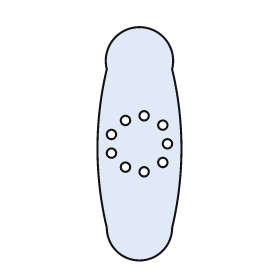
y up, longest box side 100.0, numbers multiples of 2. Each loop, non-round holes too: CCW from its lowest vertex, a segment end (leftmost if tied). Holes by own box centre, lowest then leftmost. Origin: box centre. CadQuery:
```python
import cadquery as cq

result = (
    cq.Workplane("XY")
    .moveTo(-14.0, -36.0)
    .threePointArc((0.0, -50.0), (14.0, -36.0))
    .threePointArc((18.0, -2.0), (14.0, 32.0))
    .threePointArc((0.0, 50.0), (-14.0, 32.0))
    .threePointArc((-18.0, -2.0), (-14.0, -36.0))
    .close()
    .moveTo(2.0, -12.0)
    .circle(2.0)
    .moveTo(-6.0, -10.0)
    .circle(2.0)
    .moveTo(10.0, -8.0)
    .circle(2.0)
    .moveTo(-12.0, -4.0)
    .circle(2.0)
    .moveTo(12.0, 0.0)
    .circle(2.0)
    .moveTo(-12.0, 4.0)
    .circle(2.0)
    .moveTo(10.0, 8.0)
    .circle(2.0)
    .moveTo(-6.0, 10.0)
    .circle(2.0)
    .moveTo(2.0, 12.0)
    .circle(2.0)
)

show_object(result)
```